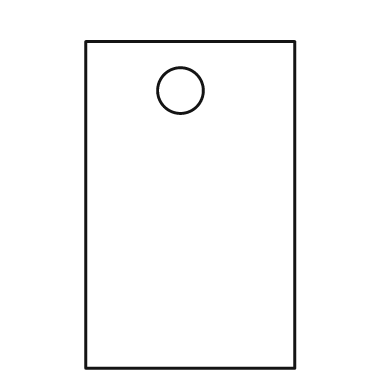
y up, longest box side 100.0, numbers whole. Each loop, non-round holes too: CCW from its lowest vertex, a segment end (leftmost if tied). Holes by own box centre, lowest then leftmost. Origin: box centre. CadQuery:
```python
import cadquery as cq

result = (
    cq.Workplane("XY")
    .moveTo(-32.0, -50.0)
    .lineTo(32.0, -50.0)
    .lineTo(32.0, 50.0)
    .lineTo(-32.0, 50.0)
    .close()
    .moveTo(-3.0, 35.0)
    .circle(7.0)
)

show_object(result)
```